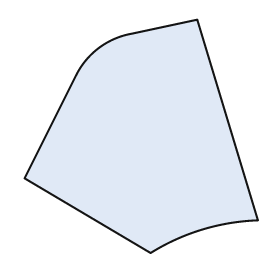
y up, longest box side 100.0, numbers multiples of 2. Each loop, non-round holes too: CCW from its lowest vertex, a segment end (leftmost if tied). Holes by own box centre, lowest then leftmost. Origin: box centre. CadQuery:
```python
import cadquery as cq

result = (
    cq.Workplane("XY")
    .moveTo(4.0, -50.0)
    .threePointArc((26.0, -40.0), (50.0, -36.0))
    .lineTo(24.0, 50.0)
    .lineTo(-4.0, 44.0)
    .threePointArc((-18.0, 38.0), (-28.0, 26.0))
    .lineTo(-50.0, -18.0)
    .close()
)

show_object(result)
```